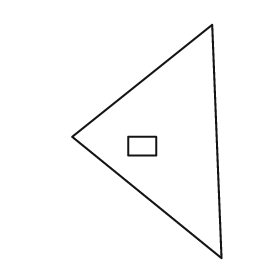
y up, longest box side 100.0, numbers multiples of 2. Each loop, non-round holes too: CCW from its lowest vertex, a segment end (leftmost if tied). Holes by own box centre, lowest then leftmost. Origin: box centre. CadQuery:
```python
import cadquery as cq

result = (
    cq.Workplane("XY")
    .moveTo(32.0, -50.0)
    .lineTo(28.0, 50.0)
    .lineTo(-32.0, 2.0)
    .close()
    .moveTo(-8.0, -6.0)
    .lineTo(4.0, -6.0)
    .lineTo(4.0, 2.0)
    .lineTo(-8.0, 2.0)
    .close()
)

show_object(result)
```